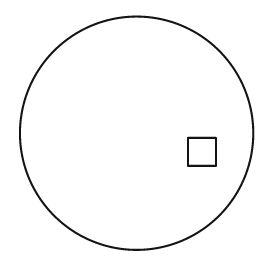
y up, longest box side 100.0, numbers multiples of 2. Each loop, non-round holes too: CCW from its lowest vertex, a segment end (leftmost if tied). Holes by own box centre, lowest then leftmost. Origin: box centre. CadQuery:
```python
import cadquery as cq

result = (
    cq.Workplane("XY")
    .moveTo(0.0, 0.0)
    .circle(50.0)
    .moveTo(22.0, -14.0)
    .lineTo(34.0, -14.0)
    .lineTo(34.0, -2.0)
    .lineTo(22.0, -2.0)
    .close()
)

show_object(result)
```